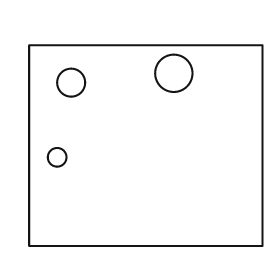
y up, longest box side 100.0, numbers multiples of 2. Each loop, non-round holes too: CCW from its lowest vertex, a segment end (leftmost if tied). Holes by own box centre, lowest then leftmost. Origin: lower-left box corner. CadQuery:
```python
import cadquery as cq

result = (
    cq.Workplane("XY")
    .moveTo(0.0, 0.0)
    .lineTo(100.0, 0.0)
    .lineTo(100.0, 86.0)
    .lineTo(0.0, 86.0)
    .close()
    .moveTo(12.0, 38.0)
    .circle(4.0)
    .moveTo(18.0, 70.0)
    .circle(6.0)
    .moveTo(62.0, 74.0)
    .circle(8.0)
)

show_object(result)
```